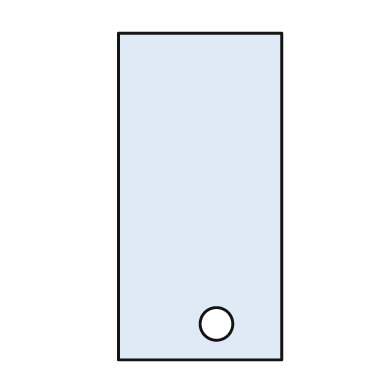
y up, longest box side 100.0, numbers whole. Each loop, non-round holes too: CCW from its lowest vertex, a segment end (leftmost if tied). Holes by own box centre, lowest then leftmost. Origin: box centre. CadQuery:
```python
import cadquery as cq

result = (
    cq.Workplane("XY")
    .moveTo(-25.0, -50.0)
    .lineTo(25.0, -50.0)
    .lineTo(25.0, 50.0)
    .lineTo(-25.0, 50.0)
    .close()
    .moveTo(5.0, -39.0)
    .circle(5.0)
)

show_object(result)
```